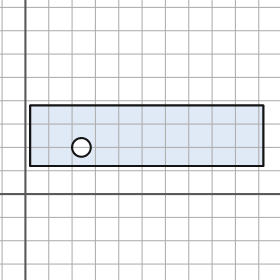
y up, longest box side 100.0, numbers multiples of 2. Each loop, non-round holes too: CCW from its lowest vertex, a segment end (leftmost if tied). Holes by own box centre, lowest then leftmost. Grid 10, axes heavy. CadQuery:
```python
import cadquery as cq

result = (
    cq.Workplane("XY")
    .moveTo(2.0, 12.0)
    .lineTo(102.0, 12.0)
    .lineTo(102.0, 38.0)
    .lineTo(2.0, 38.0)
    .close()
    .moveTo(24.0, 20.0)
    .circle(4.0)
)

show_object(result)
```